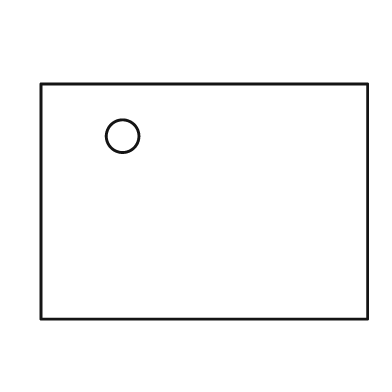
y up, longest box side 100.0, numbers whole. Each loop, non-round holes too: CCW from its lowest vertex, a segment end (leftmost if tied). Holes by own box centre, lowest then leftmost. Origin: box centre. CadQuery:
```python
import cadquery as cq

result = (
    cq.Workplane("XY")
    .moveTo(-50.0, -36.0)
    .lineTo(50.0, -36.0)
    .lineTo(50.0, 36.0)
    .lineTo(-50.0, 36.0)
    .close()
    .moveTo(-25.0, 20.0)
    .circle(5.0)
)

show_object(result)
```